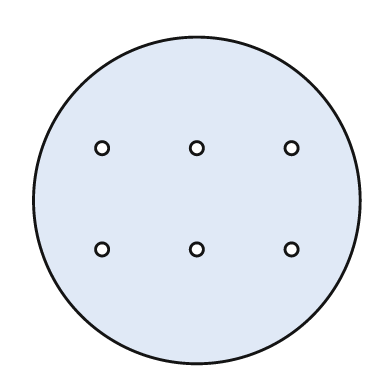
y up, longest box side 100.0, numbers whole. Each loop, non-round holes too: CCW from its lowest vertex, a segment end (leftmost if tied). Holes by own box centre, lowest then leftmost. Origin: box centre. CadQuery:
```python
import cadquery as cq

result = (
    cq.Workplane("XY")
    .moveTo(0.0, 0.0)
    .circle(50.0)
    .moveTo(-29.0, -15.0)
    .circle(2.0)
    .moveTo(0.0, -15.0)
    .circle(2.0)
    .moveTo(29.0, -15.0)
    .circle(2.0)
    .moveTo(-29.0, 16.0)
    .circle(2.0)
    .moveTo(0.0, 16.0)
    .circle(2.0)
    .moveTo(29.0, 16.0)
    .circle(2.0)
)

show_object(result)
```